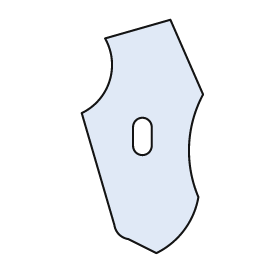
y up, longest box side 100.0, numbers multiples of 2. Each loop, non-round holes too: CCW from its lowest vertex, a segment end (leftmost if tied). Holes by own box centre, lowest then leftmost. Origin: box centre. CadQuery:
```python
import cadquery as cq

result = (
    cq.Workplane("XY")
    .moveTo(6.0, -50.0)
    .threePointArc((18.0, -40.0), (24.0, -26.0))
    .threePointArc((20.0, -4.0), (26.0, 18.0))
    .lineTo(12.0, 50.0)
    .lineTo(-16.0, 42.0)
    .threePointArc((-14.0, 24.0), (-26.0, 10.0))
    .lineTo(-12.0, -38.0)
    .threePointArc((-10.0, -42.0), (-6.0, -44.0))
    .close()
    .moveTo(-4.0, -4.0)
    .threePointArc((0.0, -8.0), (4.0, -4.0))
    .lineTo(4.0, 4.0)
    .threePointArc((0.0, 8.0), (-4.0, 4.0))
    .close()
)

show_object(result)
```